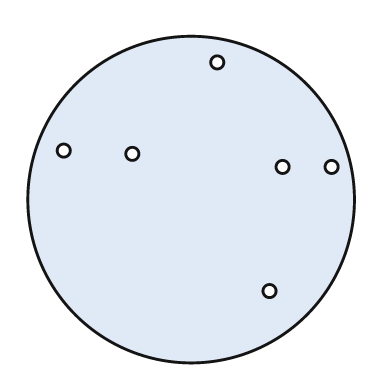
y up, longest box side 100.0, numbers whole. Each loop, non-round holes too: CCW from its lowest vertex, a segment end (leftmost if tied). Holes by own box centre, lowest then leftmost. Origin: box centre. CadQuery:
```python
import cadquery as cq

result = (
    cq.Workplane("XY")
    .moveTo(0.0, 0.0)
    .circle(50.0)
    .moveTo(24.0, -28.0)
    .circle(2.0)
    .moveTo(28.0, 10.0)
    .circle(2.0)
    .moveTo(43.0, 10.0)
    .circle(2.0)
    .moveTo(-18.0, 14.0)
    .circle(2.0)
    .moveTo(-39.0, 15.0)
    .circle(2.0)
    .moveTo(8.0, 42.0)
    .circle(2.0)
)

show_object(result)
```